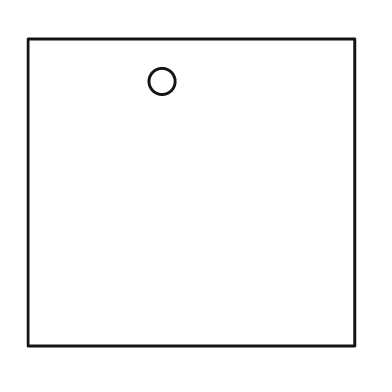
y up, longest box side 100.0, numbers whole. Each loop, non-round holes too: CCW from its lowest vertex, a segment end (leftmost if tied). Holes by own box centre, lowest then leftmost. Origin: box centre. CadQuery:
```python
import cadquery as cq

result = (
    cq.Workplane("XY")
    .moveTo(-50.0, -47.0)
    .lineTo(50.0, -47.0)
    .lineTo(50.0, 47.0)
    .lineTo(-50.0, 47.0)
    .close()
    .moveTo(-9.0, 34.0)
    .circle(4.0)
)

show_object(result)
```